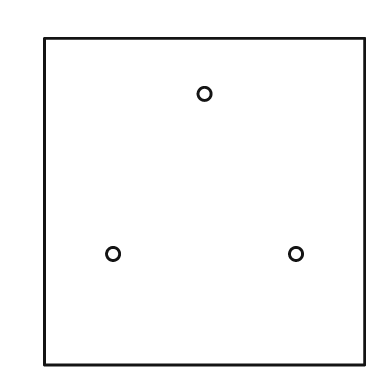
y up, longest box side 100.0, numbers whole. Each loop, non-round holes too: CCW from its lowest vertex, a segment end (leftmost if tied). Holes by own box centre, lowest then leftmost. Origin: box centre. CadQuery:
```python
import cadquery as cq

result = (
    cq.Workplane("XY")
    .moveTo(-49.0, -50.0)
    .lineTo(49.0, -50.0)
    .lineTo(49.0, 50.0)
    .lineTo(-49.0, 50.0)
    .close()
    .moveTo(-28.0, -16.0)
    .circle(2.0)
    .moveTo(28.0, -16.0)
    .circle(2.0)
    .moveTo(0.0, 33.0)
    .circle(2.0)
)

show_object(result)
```